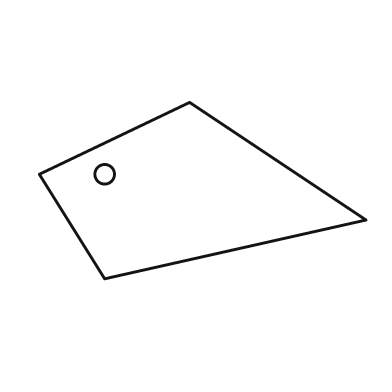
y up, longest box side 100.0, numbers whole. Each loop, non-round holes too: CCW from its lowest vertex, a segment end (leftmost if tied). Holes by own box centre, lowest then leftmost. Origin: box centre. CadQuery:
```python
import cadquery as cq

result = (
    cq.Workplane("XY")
    .moveTo(-30.0, -27.0)
    .lineTo(50.0, -9.0)
    .lineTo(-4.0, 27.0)
    .lineTo(-50.0, 5.0)
    .close()
    .moveTo(-30.0, 5.0)
    .circle(3.0)
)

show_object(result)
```